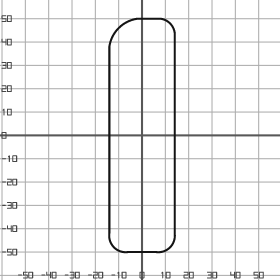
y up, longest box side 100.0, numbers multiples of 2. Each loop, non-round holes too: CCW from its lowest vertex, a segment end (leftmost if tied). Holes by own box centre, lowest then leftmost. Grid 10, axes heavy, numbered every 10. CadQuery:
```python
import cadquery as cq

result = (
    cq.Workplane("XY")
    .moveTo(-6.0, -50.0)
    .lineTo(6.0, -50.0)
    .threePointArc((12.0, -48.0), (14.0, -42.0))
    .lineTo(14.0, 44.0)
    .threePointArc((12.0, 48.0), (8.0, 50.0))
    .lineTo(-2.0, 50.0)
    .threePointArc((-10.0, 46.0), (-14.0, 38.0))
    .lineTo(-14.0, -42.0)
    .threePointArc((-12.0, -48.0), (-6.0, -50.0))
    .close()
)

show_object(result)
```